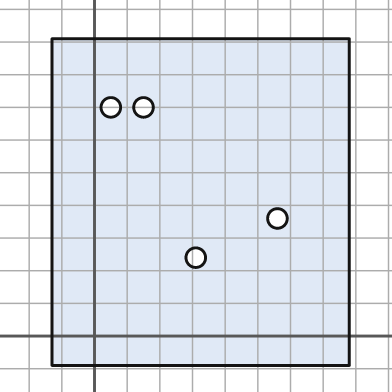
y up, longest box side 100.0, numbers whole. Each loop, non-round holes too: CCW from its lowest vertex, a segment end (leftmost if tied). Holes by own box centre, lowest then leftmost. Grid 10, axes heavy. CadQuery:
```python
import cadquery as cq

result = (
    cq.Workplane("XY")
    .moveTo(-13.0, -9.0)
    .lineTo(78.0, -9.0)
    .lineTo(78.0, 91.0)
    .lineTo(-13.0, 91.0)
    .close()
    .moveTo(31.0, 24.0)
    .circle(3.0)
    .moveTo(56.0, 36.0)
    .circle(3.0)
    .moveTo(5.0, 70.0)
    .circle(3.0)
    .moveTo(15.0, 70.0)
    .circle(3.0)
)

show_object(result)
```